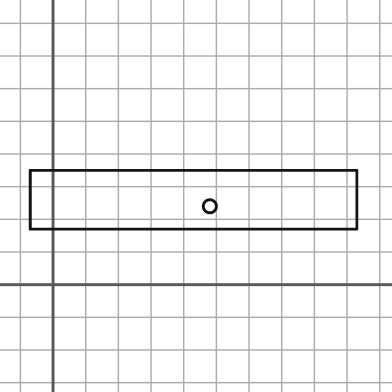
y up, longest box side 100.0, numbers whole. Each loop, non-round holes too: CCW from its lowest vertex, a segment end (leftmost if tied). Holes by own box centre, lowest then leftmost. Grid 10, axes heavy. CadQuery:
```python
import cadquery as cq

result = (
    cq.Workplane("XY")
    .moveTo(-7.0, 17.0)
    .lineTo(93.0, 17.0)
    .lineTo(93.0, 35.0)
    .lineTo(-7.0, 35.0)
    .close()
    .moveTo(48.0, 24.0)
    .circle(2.0)
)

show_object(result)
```